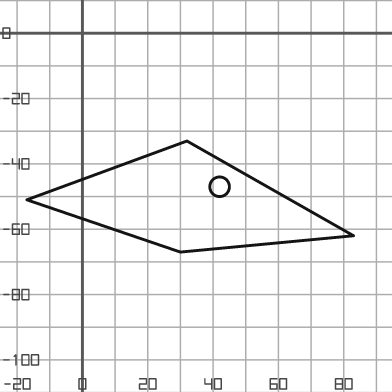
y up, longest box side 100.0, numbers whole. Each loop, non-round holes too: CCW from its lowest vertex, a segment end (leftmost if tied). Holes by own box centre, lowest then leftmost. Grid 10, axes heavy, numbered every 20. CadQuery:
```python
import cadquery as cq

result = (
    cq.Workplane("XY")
    .moveTo(30.0, -67.0)
    .lineTo(83.0, -62.0)
    .lineTo(32.0, -33.0)
    .lineTo(-17.0, -51.0)
    .close()
    .moveTo(42.0, -47.0)
    .circle(3.0)
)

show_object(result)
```